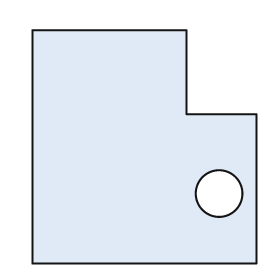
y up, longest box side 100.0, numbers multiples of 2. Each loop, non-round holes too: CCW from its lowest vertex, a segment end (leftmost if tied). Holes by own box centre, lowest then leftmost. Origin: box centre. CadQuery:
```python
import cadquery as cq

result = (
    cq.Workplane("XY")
    .moveTo(-48.0, -50.0)
    .lineTo(48.0, -50.0)
    .lineTo(48.0, 14.0)
    .lineTo(18.0, 14.0)
    .lineTo(18.0, 50.0)
    .lineTo(-48.0, 50.0)
    .close()
    .moveTo(32.0, -20.0)
    .circle(10.0)
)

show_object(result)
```